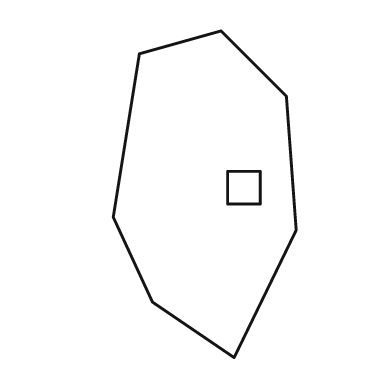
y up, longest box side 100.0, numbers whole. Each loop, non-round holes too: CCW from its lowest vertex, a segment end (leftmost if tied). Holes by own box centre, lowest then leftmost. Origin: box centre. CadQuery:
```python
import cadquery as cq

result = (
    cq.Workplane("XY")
    .moveTo(9.0, -50.0)
    .lineTo(28.0, -11.0)
    .lineTo(25.0, 30.0)
    .lineTo(5.0, 50.0)
    .lineTo(-20.0, 43.0)
    .lineTo(-28.0, -7.0)
    .lineTo(-16.0, -33.0)
    .close()
    .moveTo(7.0, -3.0)
    .lineTo(17.0, -3.0)
    .lineTo(17.0, 7.0)
    .lineTo(7.0, 7.0)
    .close()
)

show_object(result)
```